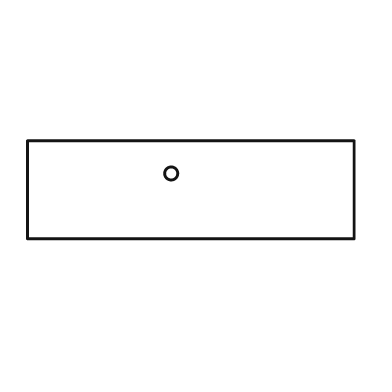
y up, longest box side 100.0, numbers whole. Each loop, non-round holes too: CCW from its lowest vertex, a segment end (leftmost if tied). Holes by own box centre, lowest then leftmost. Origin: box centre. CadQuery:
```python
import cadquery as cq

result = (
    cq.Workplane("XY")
    .moveTo(-50.0, -15.0)
    .lineTo(50.0, -15.0)
    .lineTo(50.0, 15.0)
    .lineTo(-50.0, 15.0)
    .close()
    .moveTo(-6.0, 5.0)
    .circle(2.0)
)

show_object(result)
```